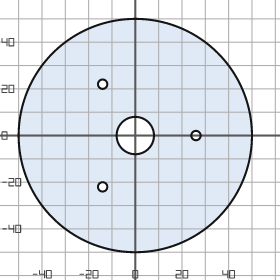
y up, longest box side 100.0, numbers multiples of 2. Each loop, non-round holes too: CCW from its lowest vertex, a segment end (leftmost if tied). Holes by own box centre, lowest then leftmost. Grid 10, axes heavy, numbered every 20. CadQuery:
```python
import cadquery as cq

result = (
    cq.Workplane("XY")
    .moveTo(0.0, 0.0)
    .circle(50.0)
    .moveTo(-14.0, -22.0)
    .circle(2.0)
    .moveTo(0.0, 0.0)
    .circle(8.0)
    .moveTo(26.0, 0.0)
    .circle(2.0)
    .moveTo(-14.0, 22.0)
    .circle(2.0)
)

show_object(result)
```